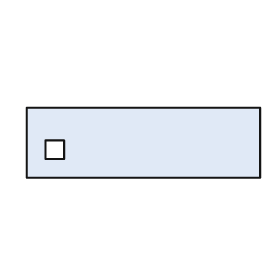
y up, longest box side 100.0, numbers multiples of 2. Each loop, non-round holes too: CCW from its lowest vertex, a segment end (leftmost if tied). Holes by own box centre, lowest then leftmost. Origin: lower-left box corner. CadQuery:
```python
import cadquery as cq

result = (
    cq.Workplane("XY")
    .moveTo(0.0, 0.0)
    .lineTo(100.0, 0.0)
    .lineTo(100.0, 30.0)
    .lineTo(0.0, 30.0)
    .close()
    .moveTo(8.0, 8.0)
    .lineTo(16.0, 8.0)
    .lineTo(16.0, 16.0)
    .lineTo(8.0, 16.0)
    .close()
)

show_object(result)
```